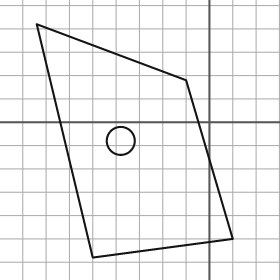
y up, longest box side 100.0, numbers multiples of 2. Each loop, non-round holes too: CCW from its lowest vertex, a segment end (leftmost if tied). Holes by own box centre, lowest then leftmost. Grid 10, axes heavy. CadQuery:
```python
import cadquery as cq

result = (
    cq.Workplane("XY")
    .moveTo(-50.0, -58.0)
    .lineTo(10.0, -50.0)
    .lineTo(-10.0, 18.0)
    .lineTo(-74.0, 42.0)
    .close()
    .moveTo(-38.0, -8.0)
    .circle(6.0)
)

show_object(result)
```